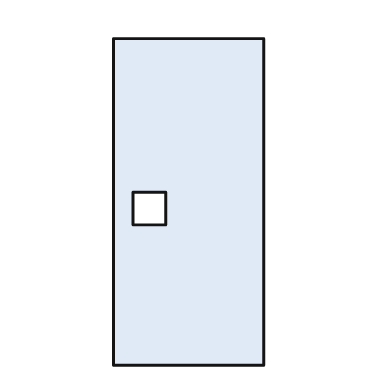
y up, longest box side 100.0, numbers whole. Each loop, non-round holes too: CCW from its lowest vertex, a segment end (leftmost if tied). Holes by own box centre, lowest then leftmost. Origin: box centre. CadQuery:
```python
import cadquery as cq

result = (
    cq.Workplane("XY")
    .moveTo(-23.0, -50.0)
    .lineTo(23.0, -50.0)
    .lineTo(23.0, 50.0)
    .lineTo(-23.0, 50.0)
    .close()
    .moveTo(-17.0, -7.0)
    .lineTo(-7.0, -7.0)
    .lineTo(-7.0, 3.0)
    .lineTo(-17.0, 3.0)
    .close()
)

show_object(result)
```